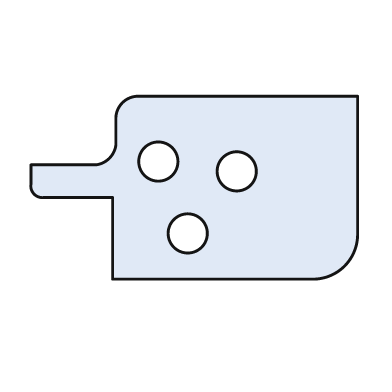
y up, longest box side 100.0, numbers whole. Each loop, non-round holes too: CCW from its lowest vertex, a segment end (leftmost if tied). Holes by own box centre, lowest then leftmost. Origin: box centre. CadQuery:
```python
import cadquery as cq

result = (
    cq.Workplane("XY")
    .moveTo(-25.0, -28.0)
    .lineTo(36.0, -28.0)
    .threePointArc((46.0, -24.0), (50.0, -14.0))
    .lineTo(50.0, 28.0)
    .lineTo(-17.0, 28.0)
    .threePointArc((-22.0, 26.0), (-24.0, 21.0))
    .lineTo(-24.0, 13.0)
    .threePointArc((-26.0, 9.0), (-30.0, 7.0))
    .lineTo(-50.0, 7.0)
    .lineTo(-50.0, 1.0)
    .threePointArc((-49.0, -2.0), (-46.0, -3.0))
    .lineTo(-25.0, -3.0)
    .close()
    .moveTo(-2.0, -14.0)
    .circle(6.0)
    .moveTo(13.0, 5.0)
    .circle(6.0)
    .moveTo(-11.0, 8.0)
    .circle(6.0)
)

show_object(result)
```